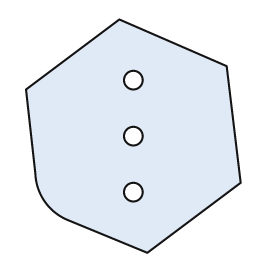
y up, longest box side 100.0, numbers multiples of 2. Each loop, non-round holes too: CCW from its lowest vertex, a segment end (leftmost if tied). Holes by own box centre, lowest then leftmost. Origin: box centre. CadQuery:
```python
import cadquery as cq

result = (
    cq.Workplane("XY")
    .moveTo(6.0, -50.0)
    .lineTo(46.0, -20.0)
    .lineTo(40.0, 30.0)
    .lineTo(-6.0, 50.0)
    .lineTo(-46.0, 20.0)
    .lineTo(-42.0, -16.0)
    .threePointArc((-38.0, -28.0), (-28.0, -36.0))
    .close()
    .moveTo(0.0, -24.0)
    .circle(4.0)
    .moveTo(0.0, 0.0)
    .circle(4.0)
    .moveTo(0.0, 24.0)
    .circle(4.0)
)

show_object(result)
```